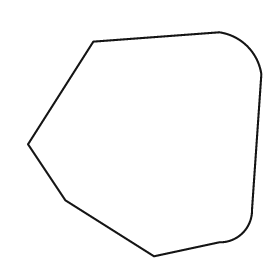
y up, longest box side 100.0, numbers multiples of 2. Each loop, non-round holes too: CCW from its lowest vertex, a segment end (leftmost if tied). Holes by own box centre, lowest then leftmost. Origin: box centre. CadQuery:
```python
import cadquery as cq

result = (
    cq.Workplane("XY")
    .moveTo(4.0, -48.0)
    .lineTo(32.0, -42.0)
    .threePointArc((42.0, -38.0), (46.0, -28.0))
    .lineTo(50.0, 30.0)
    .threePointArc((44.0, 42.0), (32.0, 48.0))
    .lineTo(-22.0, 44.0)
    .lineTo(-50.0, 0.0)
    .lineTo(-34.0, -24.0)
    .close()
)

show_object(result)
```